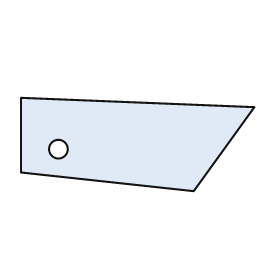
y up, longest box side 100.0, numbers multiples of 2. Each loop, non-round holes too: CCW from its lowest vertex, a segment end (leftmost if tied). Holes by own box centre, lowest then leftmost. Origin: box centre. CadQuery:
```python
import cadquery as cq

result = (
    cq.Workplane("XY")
    .moveTo(24.0, -20.0)
    .lineTo(50.0, 16.0)
    .lineTo(-50.0, 20.0)
    .lineTo(-50.0, -12.0)
    .close()
    .moveTo(-34.0, -2.0)
    .circle(4.0)
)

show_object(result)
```